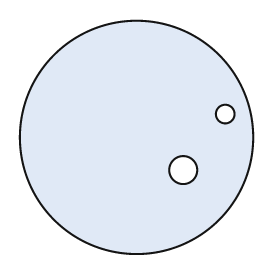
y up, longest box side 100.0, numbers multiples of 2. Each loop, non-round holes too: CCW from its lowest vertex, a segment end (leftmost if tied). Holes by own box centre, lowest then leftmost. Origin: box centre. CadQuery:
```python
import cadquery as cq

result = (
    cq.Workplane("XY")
    .moveTo(0.0, 0.0)
    .circle(50.0)
    .moveTo(20.0, -14.0)
    .circle(6.0)
    .moveTo(38.0, 10.0)
    .circle(4.0)
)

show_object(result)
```